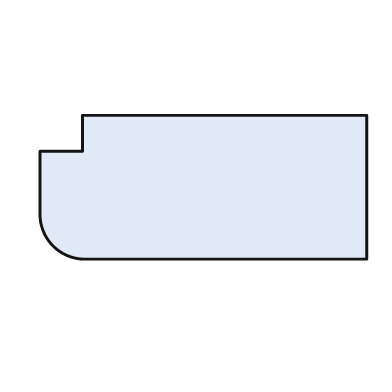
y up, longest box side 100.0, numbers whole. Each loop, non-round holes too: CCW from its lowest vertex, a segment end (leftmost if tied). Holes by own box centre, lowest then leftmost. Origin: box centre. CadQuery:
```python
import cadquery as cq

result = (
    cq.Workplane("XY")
    .moveTo(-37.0, -22.0)
    .lineTo(50.0, -22.0)
    .lineTo(50.0, 22.0)
    .lineTo(-37.0, 22.0)
    .lineTo(-37.0, 11.0)
    .lineTo(-50.0, 11.0)
    .lineTo(-50.0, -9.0)
    .threePointArc((-46.0, -18.0), (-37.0, -22.0))
    .close()
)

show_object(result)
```